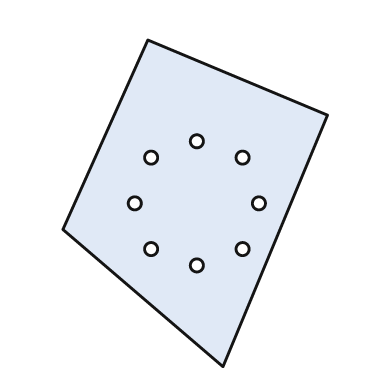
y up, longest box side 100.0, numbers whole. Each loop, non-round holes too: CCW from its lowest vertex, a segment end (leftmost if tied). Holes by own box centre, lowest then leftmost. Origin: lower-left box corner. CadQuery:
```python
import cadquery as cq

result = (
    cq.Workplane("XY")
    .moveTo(49.0, 0.0)
    .lineTo(81.0, 77.0)
    .lineTo(26.0, 100.0)
    .lineTo(0.0, 42.0)
    .close()
    .moveTo(41.0, 31.0)
    .circle(2.0)
    .moveTo(27.0, 36.0)
    .circle(2.0)
    .moveTo(55.0, 36.0)
    .circle(2.0)
    .moveTo(22.0, 50.0)
    .circle(2.0)
    .moveTo(60.0, 50.0)
    .circle(2.0)
    .moveTo(27.0, 64.0)
    .circle(2.0)
    .moveTo(55.0, 64.0)
    .circle(2.0)
    .moveTo(41.0, 69.0)
    .circle(2.0)
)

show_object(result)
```